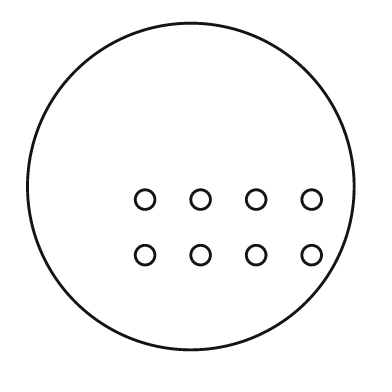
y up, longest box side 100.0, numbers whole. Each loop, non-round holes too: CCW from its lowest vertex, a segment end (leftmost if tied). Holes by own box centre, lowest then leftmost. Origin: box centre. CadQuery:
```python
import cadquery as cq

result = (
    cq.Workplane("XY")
    .moveTo(0.0, 0.0)
    .circle(50.0)
    .moveTo(-14.0, -21.0)
    .circle(3.0)
    .moveTo(3.0, -21.0)
    .circle(3.0)
    .moveTo(20.0, -21.0)
    .circle(3.0)
    .moveTo(37.0, -21.0)
    .circle(3.0)
    .moveTo(-14.0, -4.0)
    .circle(3.0)
    .moveTo(3.0, -4.0)
    .circle(3.0)
    .moveTo(20.0, -4.0)
    .circle(3.0)
    .moveTo(37.0, -4.0)
    .circle(3.0)
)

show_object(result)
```